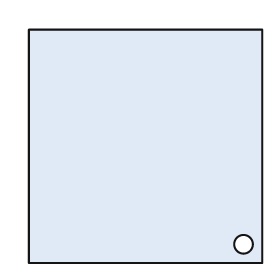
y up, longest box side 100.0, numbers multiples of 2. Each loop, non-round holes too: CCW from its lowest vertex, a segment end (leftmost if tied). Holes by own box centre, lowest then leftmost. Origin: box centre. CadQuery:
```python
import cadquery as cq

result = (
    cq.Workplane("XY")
    .moveTo(-50.0, -50.0)
    .lineTo(50.0, -50.0)
    .lineTo(50.0, 50.0)
    .lineTo(-50.0, 50.0)
    .close()
    .moveTo(42.0, -42.0)
    .circle(4.0)
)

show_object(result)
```